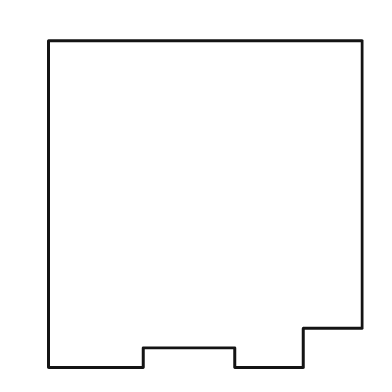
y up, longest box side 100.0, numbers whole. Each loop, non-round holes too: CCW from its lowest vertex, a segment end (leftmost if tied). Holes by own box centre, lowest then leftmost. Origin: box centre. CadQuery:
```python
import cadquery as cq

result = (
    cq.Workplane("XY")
    .moveTo(-48.0, -50.0)
    .lineTo(-19.0, -50.0)
    .lineTo(-19.0, -44.0)
    .lineTo(9.0, -44.0)
    .lineTo(9.0, -50.0)
    .lineTo(30.0, -50.0)
    .lineTo(30.0, -38.0)
    .lineTo(48.0, -38.0)
    .lineTo(48.0, 50.0)
    .lineTo(-48.0, 50.0)
    .close()
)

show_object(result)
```